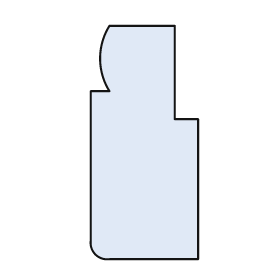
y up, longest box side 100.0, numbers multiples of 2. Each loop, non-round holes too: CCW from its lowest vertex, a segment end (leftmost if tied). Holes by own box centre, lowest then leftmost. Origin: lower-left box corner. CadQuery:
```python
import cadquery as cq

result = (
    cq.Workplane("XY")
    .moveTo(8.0, 0.0)
    .lineTo(46.0, 0.0)
    .lineTo(46.0, 60.0)
    .lineTo(36.0, 60.0)
    .lineTo(36.0, 100.0)
    .lineTo(8.0, 100.0)
    .threePointArc((4.0, 86.0), (8.0, 72.0))
    .lineTo(0.0, 72.0)
    .lineTo(0.0, 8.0)
    .threePointArc((2.0, 2.0), (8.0, 0.0))
    .close()
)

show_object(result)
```